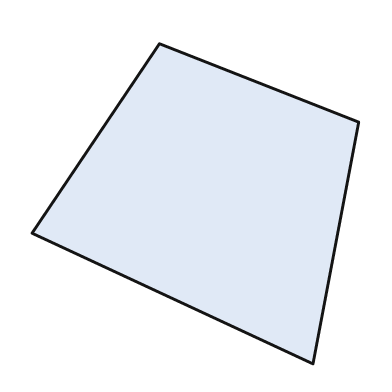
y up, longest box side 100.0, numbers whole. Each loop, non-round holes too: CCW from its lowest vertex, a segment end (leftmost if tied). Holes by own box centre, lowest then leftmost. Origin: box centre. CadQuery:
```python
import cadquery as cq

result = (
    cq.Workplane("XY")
    .moveTo(36.0, -49.0)
    .lineTo(50.0, 25.0)
    .lineTo(-11.0, 49.0)
    .lineTo(-50.0, -9.0)
    .close()
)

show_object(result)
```